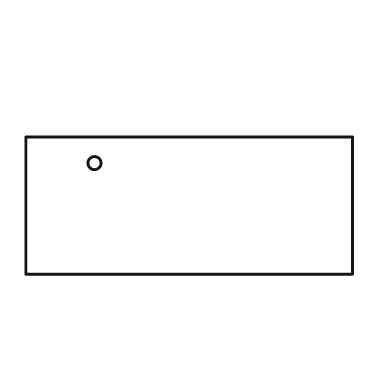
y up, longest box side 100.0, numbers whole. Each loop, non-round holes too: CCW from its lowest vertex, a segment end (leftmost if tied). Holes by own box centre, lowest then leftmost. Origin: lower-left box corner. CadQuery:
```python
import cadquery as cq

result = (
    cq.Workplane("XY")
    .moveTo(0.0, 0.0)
    .lineTo(100.0, 0.0)
    .lineTo(100.0, 42.0)
    .lineTo(0.0, 42.0)
    .close()
    .moveTo(21.0, 34.0)
    .circle(2.0)
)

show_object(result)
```